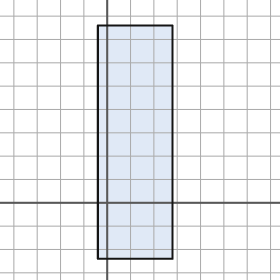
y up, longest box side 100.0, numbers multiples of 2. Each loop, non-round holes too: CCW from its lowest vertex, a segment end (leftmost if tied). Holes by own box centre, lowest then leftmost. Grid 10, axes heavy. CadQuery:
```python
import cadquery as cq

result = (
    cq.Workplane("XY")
    .moveTo(-4.0, -24.0)
    .lineTo(28.0, -24.0)
    .lineTo(28.0, 76.0)
    .lineTo(-4.0, 76.0)
    .close()
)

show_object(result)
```